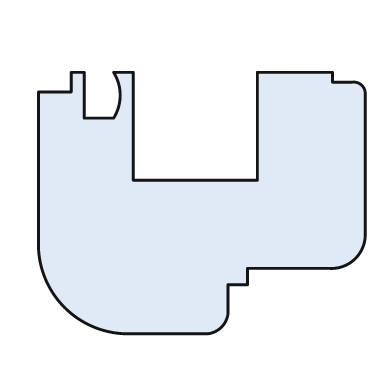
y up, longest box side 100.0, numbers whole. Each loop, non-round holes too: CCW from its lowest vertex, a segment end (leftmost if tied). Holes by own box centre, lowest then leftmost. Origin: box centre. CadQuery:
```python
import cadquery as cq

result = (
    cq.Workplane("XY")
    .moveTo(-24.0, -40.0)
    .lineTo(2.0, -40.0)
    .threePointArc((6.0, -38.0), (8.0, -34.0))
    .lineTo(8.0, -25.0)
    .lineTo(14.0, -25.0)
    .lineTo(14.0, -20.0)
    .lineTo(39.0, -20.0)
    .threePointArc((47.0, -17.0), (50.0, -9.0))
    .lineTo(50.0, 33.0)
    .threePointArc((49.0, 36.0), (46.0, 37.0))
    .lineTo(40.0, 37.0)
    .lineTo(40.0, 40.0)
    .lineTo(17.0, 40.0)
    .lineTo(17.0, 7.0)
    .lineTo(-21.0, 7.0)
    .lineTo(-21.0, 40.0)
    .lineTo(-27.0, 40.0)
    .threePointArc((-25.0, 33.0), (-27.0, 26.0))
    .lineTo(-36.0, 26.0)
    .lineTo(-36.0, 40.0)
    .lineTo(-40.0, 40.0)
    .lineTo(-40.0, 34.0)
    .lineTo(-50.0, 34.0)
    .lineTo(-50.0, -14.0)
    .threePointArc((-42.0, -32.0), (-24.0, -40.0))
    .close()
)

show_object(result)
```